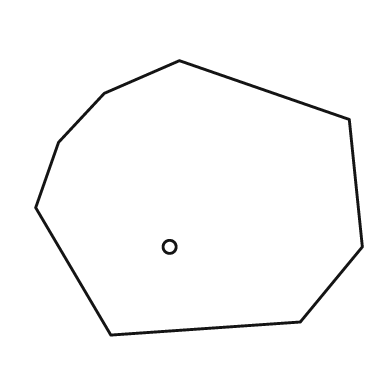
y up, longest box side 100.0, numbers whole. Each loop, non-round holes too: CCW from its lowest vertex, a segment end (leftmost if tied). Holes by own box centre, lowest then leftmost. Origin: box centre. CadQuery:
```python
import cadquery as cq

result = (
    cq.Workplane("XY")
    .moveTo(-27.0, -42.0)
    .lineTo(31.0, -38.0)
    .lineTo(50.0, -15.0)
    .lineTo(46.0, 24.0)
    .lineTo(-6.0, 42.0)
    .lineTo(-29.0, 32.0)
    .lineTo(-43.0, 17.0)
    .lineTo(-50.0, -3.0)
    .close()
    .moveTo(-9.0, -15.0)
    .circle(2.0)
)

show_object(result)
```